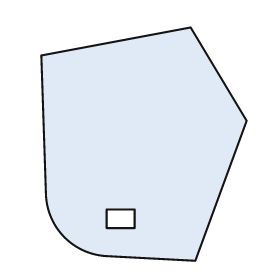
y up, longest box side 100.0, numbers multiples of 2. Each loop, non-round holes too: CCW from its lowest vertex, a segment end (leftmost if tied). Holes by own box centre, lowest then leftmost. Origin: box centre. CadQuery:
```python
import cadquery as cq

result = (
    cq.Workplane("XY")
    .moveTo(22.0, -50.0)
    .lineTo(44.0, 10.0)
    .lineTo(20.0, 50.0)
    .lineTo(-44.0, 38.0)
    .lineTo(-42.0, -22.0)
    .threePointArc((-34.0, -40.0), (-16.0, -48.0))
    .close()
    .moveTo(-16.0, -36.0)
    .lineTo(-4.0, -36.0)
    .lineTo(-4.0, -28.0)
    .lineTo(-16.0, -28.0)
    .close()
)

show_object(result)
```